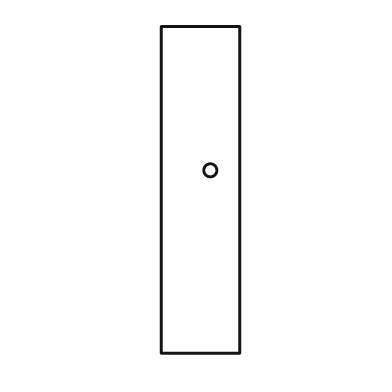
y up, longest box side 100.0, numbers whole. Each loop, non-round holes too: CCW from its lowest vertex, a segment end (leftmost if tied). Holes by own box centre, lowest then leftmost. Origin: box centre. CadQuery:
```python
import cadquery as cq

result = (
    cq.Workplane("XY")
    .moveTo(-12.0, -50.0)
    .lineTo(12.0, -50.0)
    .lineTo(12.0, 50.0)
    .lineTo(-12.0, 50.0)
    .close()
    .moveTo(3.0, 6.0)
    .circle(2.0)
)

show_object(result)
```